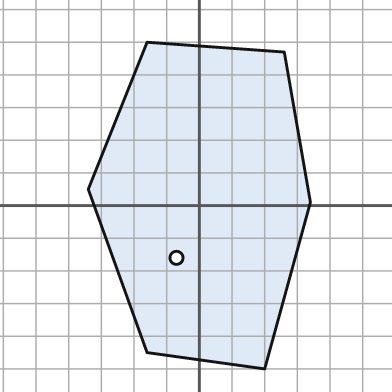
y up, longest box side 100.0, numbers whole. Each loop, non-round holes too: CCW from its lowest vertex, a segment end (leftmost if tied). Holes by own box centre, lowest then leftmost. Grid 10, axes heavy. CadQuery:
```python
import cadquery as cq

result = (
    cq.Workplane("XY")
    .moveTo(20.0, -50.0)
    .lineTo(34.0, 1.0)
    .lineTo(26.0, 47.0)
    .lineTo(-16.0, 50.0)
    .lineTo(-34.0, 5.0)
    .lineTo(-16.0, -45.0)
    .close()
    .moveTo(-7.0, -16.0)
    .circle(2.0)
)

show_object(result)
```